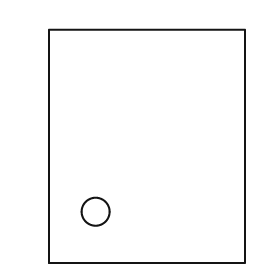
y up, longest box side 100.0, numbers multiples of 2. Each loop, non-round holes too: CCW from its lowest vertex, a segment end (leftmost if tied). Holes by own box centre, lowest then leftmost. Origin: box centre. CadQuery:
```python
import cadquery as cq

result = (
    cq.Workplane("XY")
    .moveTo(-42.0, -50.0)
    .lineTo(42.0, -50.0)
    .lineTo(42.0, 50.0)
    .lineTo(-42.0, 50.0)
    .close()
    .moveTo(-22.0, -28.0)
    .circle(6.0)
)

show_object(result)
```